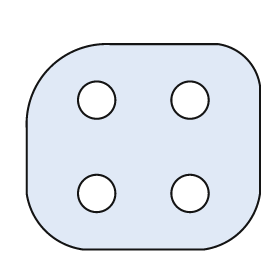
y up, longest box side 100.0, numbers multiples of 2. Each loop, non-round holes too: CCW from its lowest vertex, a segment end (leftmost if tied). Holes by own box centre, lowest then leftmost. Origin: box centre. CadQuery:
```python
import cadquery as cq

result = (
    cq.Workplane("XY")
    .moveTo(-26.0, -44.0)
    .lineTo(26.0, -44.0)
    .threePointArc((42.0, -36.0), (50.0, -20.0))
    .lineTo(50.0, 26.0)
    .threePointArc((44.0, 38.0), (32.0, 44.0))
    .lineTo(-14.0, 44.0)
    .threePointArc((-40.0, 34.0), (-50.0, 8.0))
    .lineTo(-50.0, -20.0)
    .threePointArc((-42.0, -36.0), (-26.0, -44.0))
    .close()
    .moveTo(-20.0, -20.0)
    .circle(8.0)
    .moveTo(20.0, -20.0)
    .circle(8.0)
    .moveTo(-20.0, 20.0)
    .circle(8.0)
    .moveTo(20.0, 20.0)
    .circle(8.0)
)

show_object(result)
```